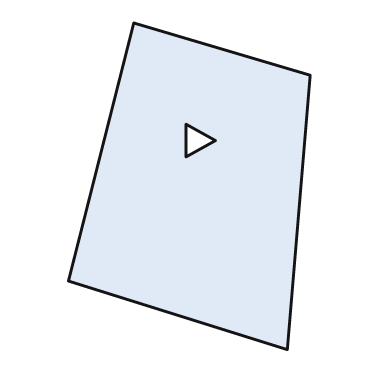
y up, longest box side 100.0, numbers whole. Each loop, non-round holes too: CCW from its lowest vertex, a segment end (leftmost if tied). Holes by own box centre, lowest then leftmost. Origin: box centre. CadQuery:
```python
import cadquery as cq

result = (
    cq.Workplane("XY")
    .moveTo(30.0, -50.0)
    .lineTo(37.0, 34.0)
    .lineTo(-17.0, 50.0)
    .lineTo(-37.0, -29.0)
    .close()
    .moveTo(-1.0, 9.0)
    .lineTo(8.0, 14.0)
    .lineTo(-1.0, 19.0)
    .close()
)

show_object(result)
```